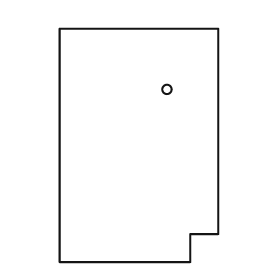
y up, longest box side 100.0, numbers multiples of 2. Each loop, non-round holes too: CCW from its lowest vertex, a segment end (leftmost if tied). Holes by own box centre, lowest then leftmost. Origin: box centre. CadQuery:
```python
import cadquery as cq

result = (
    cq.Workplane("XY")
    .moveTo(-34.0, -50.0)
    .lineTo(22.0, -50.0)
    .lineTo(22.0, -38.0)
    .lineTo(34.0, -38.0)
    .lineTo(34.0, 50.0)
    .lineTo(-34.0, 50.0)
    .close()
    .moveTo(12.0, 24.0)
    .circle(2.0)
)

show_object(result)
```